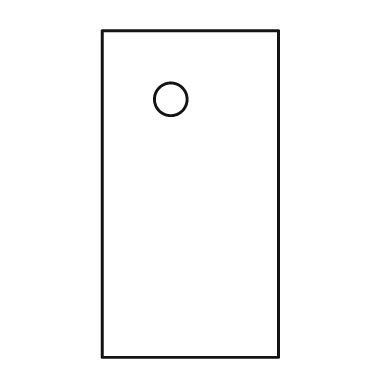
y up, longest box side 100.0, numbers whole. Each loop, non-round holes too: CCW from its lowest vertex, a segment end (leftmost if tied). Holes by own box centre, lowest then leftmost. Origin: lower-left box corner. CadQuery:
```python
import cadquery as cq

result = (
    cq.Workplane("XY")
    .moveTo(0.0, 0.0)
    .lineTo(54.0, 0.0)
    .lineTo(54.0, 100.0)
    .lineTo(0.0, 100.0)
    .close()
    .moveTo(21.0, 79.0)
    .circle(5.0)
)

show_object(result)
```